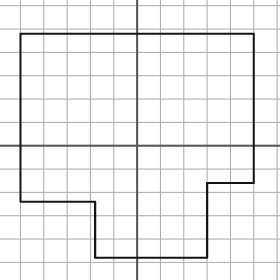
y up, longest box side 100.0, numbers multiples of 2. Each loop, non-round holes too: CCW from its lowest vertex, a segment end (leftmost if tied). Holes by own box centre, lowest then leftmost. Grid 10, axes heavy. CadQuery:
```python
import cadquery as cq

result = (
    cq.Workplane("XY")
    .moveTo(-18.0, -48.0)
    .lineTo(30.0, -48.0)
    .lineTo(30.0, -16.0)
    .lineTo(50.0, -16.0)
    .lineTo(50.0, 48.0)
    .lineTo(-50.0, 48.0)
    .lineTo(-50.0, -24.0)
    .lineTo(-18.0, -24.0)
    .close()
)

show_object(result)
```